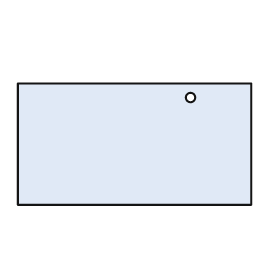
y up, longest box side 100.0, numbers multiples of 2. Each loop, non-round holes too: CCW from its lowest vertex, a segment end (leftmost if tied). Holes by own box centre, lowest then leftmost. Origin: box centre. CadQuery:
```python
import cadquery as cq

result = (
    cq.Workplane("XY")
    .moveTo(-50.0, -26.0)
    .lineTo(50.0, -26.0)
    .lineTo(50.0, 26.0)
    .lineTo(-50.0, 26.0)
    .close()
    .moveTo(24.0, 20.0)
    .circle(2.0)
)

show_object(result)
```